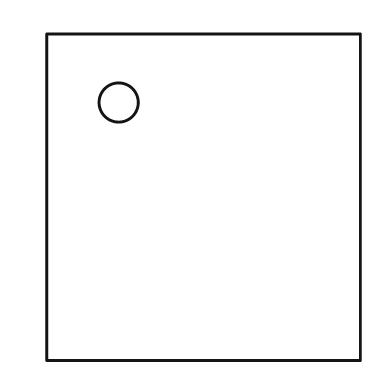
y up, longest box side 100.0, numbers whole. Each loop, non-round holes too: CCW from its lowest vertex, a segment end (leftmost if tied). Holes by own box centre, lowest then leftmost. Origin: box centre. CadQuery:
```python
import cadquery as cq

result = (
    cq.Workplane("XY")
    .moveTo(-48.0, -50.0)
    .lineTo(48.0, -50.0)
    .lineTo(48.0, 50.0)
    .lineTo(-48.0, 50.0)
    .close()
    .moveTo(-26.0, 29.0)
    .circle(6.0)
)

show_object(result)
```